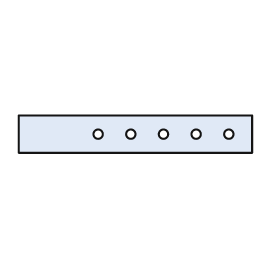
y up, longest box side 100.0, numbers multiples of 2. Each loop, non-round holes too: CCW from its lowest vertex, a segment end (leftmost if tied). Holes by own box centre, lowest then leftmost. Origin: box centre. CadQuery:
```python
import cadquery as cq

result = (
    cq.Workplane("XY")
    .moveTo(-50.0, -8.0)
    .lineTo(50.0, -8.0)
    .lineTo(50.0, 8.0)
    .lineTo(-50.0, 8.0)
    .close()
    .moveTo(-16.0, 0.0)
    .circle(2.0)
    .moveTo(-2.0, 0.0)
    .circle(2.0)
    .moveTo(12.0, 0.0)
    .circle(2.0)
    .moveTo(26.0, 0.0)
    .circle(2.0)
    .moveTo(40.0, 0.0)
    .circle(2.0)
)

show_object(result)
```